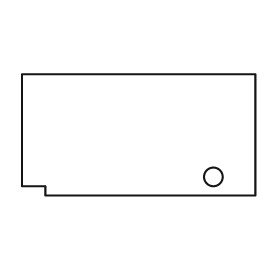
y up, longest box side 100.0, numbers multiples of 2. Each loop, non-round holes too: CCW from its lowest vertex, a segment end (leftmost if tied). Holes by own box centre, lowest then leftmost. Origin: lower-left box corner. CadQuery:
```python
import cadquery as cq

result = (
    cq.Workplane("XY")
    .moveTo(10.0, 0.0)
    .lineTo(100.0, 0.0)
    .lineTo(100.0, 52.0)
    .lineTo(0.0, 52.0)
    .lineTo(0.0, 4.0)
    .lineTo(10.0, 4.0)
    .close()
    .moveTo(82.0, 8.0)
    .circle(4.0)
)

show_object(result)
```